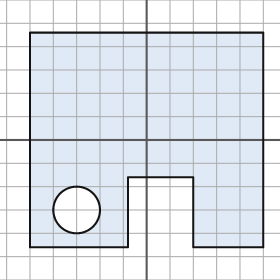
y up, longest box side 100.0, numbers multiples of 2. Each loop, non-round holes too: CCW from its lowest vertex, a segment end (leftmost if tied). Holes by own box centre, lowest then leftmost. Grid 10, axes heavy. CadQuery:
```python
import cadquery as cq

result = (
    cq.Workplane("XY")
    .moveTo(-50.0, -46.0)
    .lineTo(-8.0, -46.0)
    .lineTo(-8.0, -16.0)
    .lineTo(20.0, -16.0)
    .lineTo(20.0, -46.0)
    .lineTo(50.0, -46.0)
    .lineTo(50.0, 46.0)
    .lineTo(-50.0, 46.0)
    .close()
    .moveTo(-30.0, -30.0)
    .circle(10.0)
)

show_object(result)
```